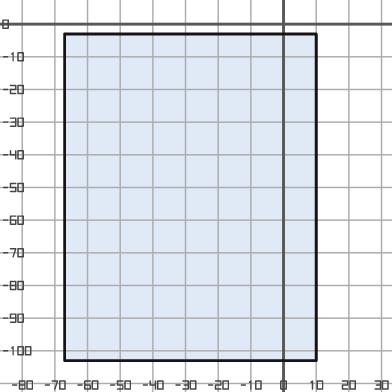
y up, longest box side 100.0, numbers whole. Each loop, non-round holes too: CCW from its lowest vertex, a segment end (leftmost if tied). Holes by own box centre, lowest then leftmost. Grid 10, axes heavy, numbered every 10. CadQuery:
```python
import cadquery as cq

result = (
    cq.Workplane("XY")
    .moveTo(-67.0, -103.0)
    .lineTo(10.0, -103.0)
    .lineTo(10.0, -3.0)
    .lineTo(-67.0, -3.0)
    .close()
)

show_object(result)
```